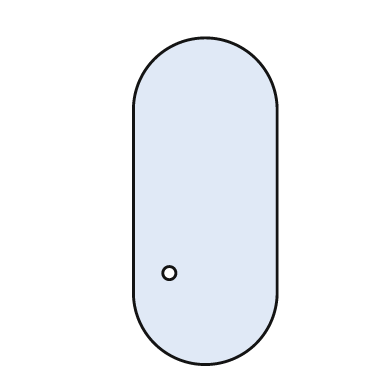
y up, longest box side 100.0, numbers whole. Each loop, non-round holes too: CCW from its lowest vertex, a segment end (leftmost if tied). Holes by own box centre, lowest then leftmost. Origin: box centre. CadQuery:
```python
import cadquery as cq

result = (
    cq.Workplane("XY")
    .moveTo(-22.0, -28.0)
    .threePointArc((0.0, -50.0), (22.0, -28.0))
    .lineTo(22.0, 28.0)
    .threePointArc((0.0, 50.0), (-22.0, 28.0))
    .close()
    .moveTo(-11.0, -22.0)
    .circle(2.0)
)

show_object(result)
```